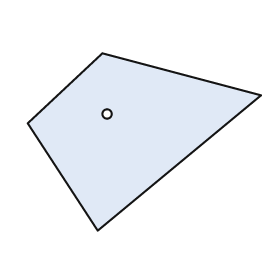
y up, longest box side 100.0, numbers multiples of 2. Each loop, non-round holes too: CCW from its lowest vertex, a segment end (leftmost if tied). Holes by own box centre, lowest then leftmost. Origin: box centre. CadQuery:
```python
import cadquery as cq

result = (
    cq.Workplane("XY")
    .moveTo(-20.0, -38.0)
    .lineTo(50.0, 20.0)
    .lineTo(-18.0, 38.0)
    .lineTo(-50.0, 8.0)
    .close()
    .moveTo(-16.0, 12.0)
    .circle(2.0)
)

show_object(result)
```